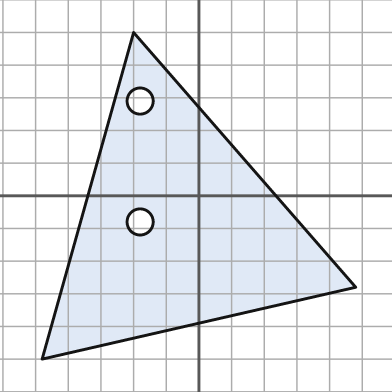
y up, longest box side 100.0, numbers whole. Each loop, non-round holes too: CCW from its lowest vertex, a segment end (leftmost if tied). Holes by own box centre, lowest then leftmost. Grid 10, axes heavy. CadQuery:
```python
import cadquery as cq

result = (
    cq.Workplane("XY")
    .moveTo(-48.0, -50.0)
    .lineTo(48.0, -28.0)
    .lineTo(-20.0, 50.0)
    .close()
    .moveTo(-18.0, -8.0)
    .circle(4.0)
    .moveTo(-18.0, 29.0)
    .circle(4.0)
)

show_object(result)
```